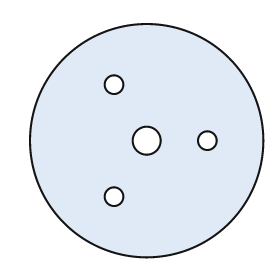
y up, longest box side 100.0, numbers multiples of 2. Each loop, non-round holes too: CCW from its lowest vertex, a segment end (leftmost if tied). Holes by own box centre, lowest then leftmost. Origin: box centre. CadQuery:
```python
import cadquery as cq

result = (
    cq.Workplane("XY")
    .moveTo(0.0, 0.0)
    .circle(50.0)
    .moveTo(-14.0, -24.0)
    .circle(4.0)
    .moveTo(0.0, 0.0)
    .circle(6.0)
    .moveTo(26.0, 0.0)
    .circle(4.0)
    .moveTo(-14.0, 24.0)
    .circle(4.0)
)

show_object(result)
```